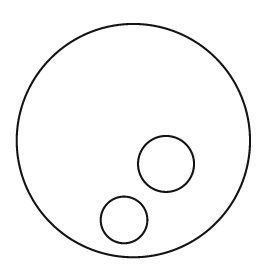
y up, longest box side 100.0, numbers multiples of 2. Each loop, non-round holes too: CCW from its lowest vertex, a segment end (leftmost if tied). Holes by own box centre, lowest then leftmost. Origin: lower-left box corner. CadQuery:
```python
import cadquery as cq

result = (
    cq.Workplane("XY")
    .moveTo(50.0, 50.0)
    .circle(50.0)
    .moveTo(46.0, 16.0)
    .circle(10.0)
    .moveTo(64.0, 40.0)
    .circle(12.0)
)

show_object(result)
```